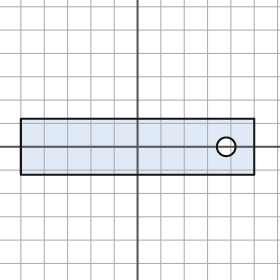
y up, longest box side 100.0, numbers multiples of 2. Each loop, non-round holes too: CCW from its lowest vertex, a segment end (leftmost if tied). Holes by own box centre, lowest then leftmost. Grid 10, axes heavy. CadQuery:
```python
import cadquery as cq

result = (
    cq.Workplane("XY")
    .moveTo(-50.0, -12.0)
    .lineTo(50.0, -12.0)
    .lineTo(50.0, 12.0)
    .lineTo(-50.0, 12.0)
    .close()
    .moveTo(38.0, 0.0)
    .circle(4.0)
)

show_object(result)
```